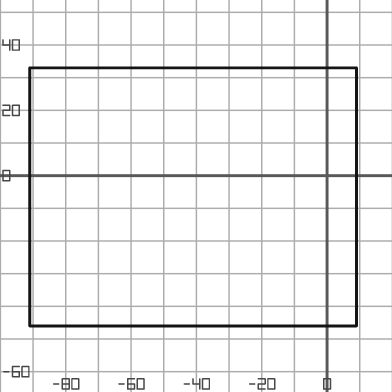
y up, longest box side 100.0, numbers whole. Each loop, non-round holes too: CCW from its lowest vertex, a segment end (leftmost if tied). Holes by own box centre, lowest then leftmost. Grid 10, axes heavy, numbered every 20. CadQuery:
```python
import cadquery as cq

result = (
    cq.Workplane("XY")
    .moveTo(-91.0, -46.0)
    .lineTo(9.0, -46.0)
    .lineTo(9.0, 33.0)
    .lineTo(-91.0, 33.0)
    .close()
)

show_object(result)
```